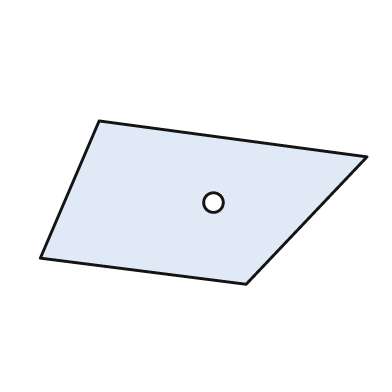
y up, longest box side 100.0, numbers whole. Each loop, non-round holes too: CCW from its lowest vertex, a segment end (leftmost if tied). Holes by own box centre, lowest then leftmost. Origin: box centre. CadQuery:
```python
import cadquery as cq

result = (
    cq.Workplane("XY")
    .moveTo(13.0, -25.0)
    .lineTo(50.0, 14.0)
    .lineTo(-32.0, 25.0)
    .lineTo(-50.0, -17.0)
    .close()
    .moveTo(3.0, 0.0)
    .circle(3.0)
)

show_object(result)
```